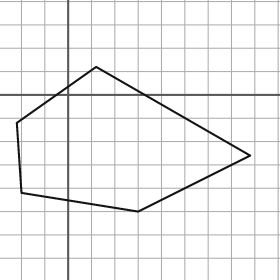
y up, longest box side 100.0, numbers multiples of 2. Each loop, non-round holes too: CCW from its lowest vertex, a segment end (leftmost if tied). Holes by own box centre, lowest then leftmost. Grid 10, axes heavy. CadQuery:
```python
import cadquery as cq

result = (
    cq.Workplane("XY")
    .moveTo(30.0, -50.0)
    .lineTo(78.0, -26.0)
    .lineTo(12.0, 12.0)
    .lineTo(-22.0, -12.0)
    .lineTo(-20.0, -42.0)
    .close()
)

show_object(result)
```